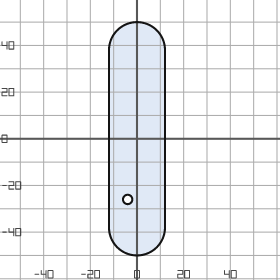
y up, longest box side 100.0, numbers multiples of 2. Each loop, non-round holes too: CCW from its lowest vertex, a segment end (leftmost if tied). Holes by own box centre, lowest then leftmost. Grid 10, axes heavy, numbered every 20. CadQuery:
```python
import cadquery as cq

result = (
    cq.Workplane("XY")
    .moveTo(-12.0, -38.0)
    .threePointArc((0.0, -50.0), (12.0, -38.0))
    .lineTo(12.0, 38.0)
    .threePointArc((0.0, 50.0), (-12.0, 38.0))
    .close()
    .moveTo(-4.0, -26.0)
    .circle(2.0)
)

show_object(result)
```